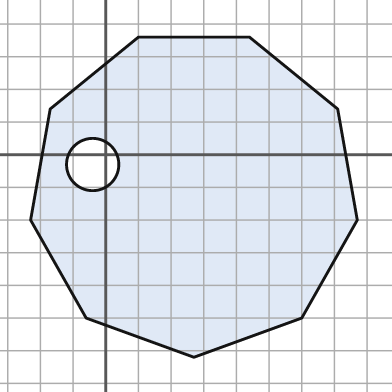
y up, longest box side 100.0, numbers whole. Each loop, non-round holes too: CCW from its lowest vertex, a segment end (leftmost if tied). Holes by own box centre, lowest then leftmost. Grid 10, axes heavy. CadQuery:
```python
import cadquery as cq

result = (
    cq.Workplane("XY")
    .moveTo(27.0, -62.0)
    .lineTo(60.0, -50.0)
    .lineTo(77.0, -20.0)
    .lineTo(71.0, 14.0)
    .lineTo(44.0, 36.0)
    .lineTo(10.0, 36.0)
    .lineTo(-17.0, 14.0)
    .lineTo(-23.0, -20.0)
    .lineTo(-6.0, -50.0)
    .close()
    .moveTo(-4.0, -3.0)
    .circle(8.0)
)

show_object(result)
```